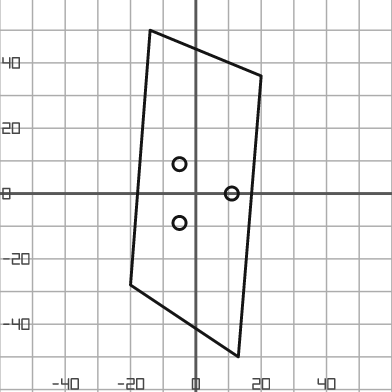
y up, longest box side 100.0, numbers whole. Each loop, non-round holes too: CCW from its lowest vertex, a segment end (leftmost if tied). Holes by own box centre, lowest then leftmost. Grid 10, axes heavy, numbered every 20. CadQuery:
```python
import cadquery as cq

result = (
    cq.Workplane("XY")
    .moveTo(13.0, -50.0)
    .lineTo(20.0, 36.0)
    .lineTo(-14.0, 50.0)
    .lineTo(-20.0, -28.0)
    .close()
    .moveTo(-5.0, -9.0)
    .circle(2.0)
    .moveTo(11.0, 0.0)
    .circle(2.0)
    .moveTo(-5.0, 9.0)
    .circle(2.0)
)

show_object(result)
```